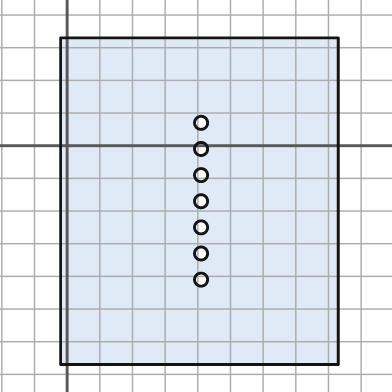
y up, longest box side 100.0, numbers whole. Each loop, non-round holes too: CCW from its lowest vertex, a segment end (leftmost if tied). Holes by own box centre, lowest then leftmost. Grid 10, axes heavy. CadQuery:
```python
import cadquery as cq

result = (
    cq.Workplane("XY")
    .moveTo(-2.0, -67.0)
    .lineTo(83.0, -67.0)
    .lineTo(83.0, 33.0)
    .lineTo(-2.0, 33.0)
    .close()
    .moveTo(41.0, -41.0)
    .circle(2.0)
    .moveTo(41.0, -33.0)
    .circle(2.0)
    .moveTo(41.0, -25.0)
    .circle(2.0)
    .moveTo(41.0, -17.0)
    .circle(2.0)
    .moveTo(41.0, -9.0)
    .circle(2.0)
    .moveTo(41.0, -1.0)
    .circle(2.0)
    .moveTo(41.0, 7.0)
    .circle(2.0)
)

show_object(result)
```